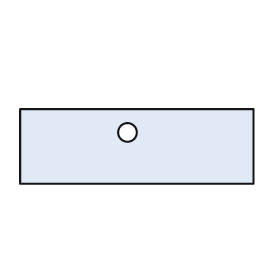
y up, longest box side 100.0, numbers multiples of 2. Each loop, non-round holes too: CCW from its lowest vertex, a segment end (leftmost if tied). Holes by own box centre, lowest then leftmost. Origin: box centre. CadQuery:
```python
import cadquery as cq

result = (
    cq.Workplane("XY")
    .moveTo(-50.0, -16.0)
    .lineTo(50.0, -16.0)
    .lineTo(50.0, 16.0)
    .lineTo(-50.0, 16.0)
    .close()
    .moveTo(-4.0, 6.0)
    .circle(4.0)
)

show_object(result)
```